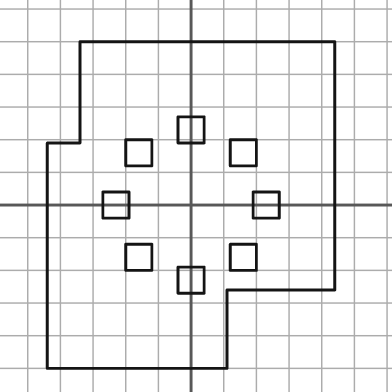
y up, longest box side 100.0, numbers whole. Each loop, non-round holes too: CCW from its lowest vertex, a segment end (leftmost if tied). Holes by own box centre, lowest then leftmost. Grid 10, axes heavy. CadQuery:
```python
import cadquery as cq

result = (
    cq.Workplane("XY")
    .moveTo(-44.0, -50.0)
    .lineTo(11.0, -50.0)
    .lineTo(11.0, -26.0)
    .lineTo(44.0, -26.0)
    .lineTo(44.0, 50.0)
    .lineTo(-34.0, 50.0)
    .lineTo(-34.0, 19.0)
    .lineTo(-44.0, 19.0)
    .close()
    .moveTo(-4.0, -27.0)
    .lineTo(4.0, -27.0)
    .lineTo(4.0, -19.0)
    .lineTo(-4.0, -19.0)
    .close()
    .moveTo(-20.0, -20.0)
    .lineTo(-12.0, -20.0)
    .lineTo(-12.0, -12.0)
    .lineTo(-20.0, -12.0)
    .close()
    .moveTo(12.0, -20.0)
    .lineTo(20.0, -20.0)
    .lineTo(20.0, -12.0)
    .lineTo(12.0, -12.0)
    .close()
    .moveTo(-27.0, -4.0)
    .lineTo(-19.0, -4.0)
    .lineTo(-19.0, 4.0)
    .lineTo(-27.0, 4.0)
    .close()
    .moveTo(19.0, -4.0)
    .lineTo(27.0, -4.0)
    .lineTo(27.0, 4.0)
    .lineTo(19.0, 4.0)
    .close()
    .moveTo(-20.0, 12.0)
    .lineTo(-12.0, 12.0)
    .lineTo(-12.0, 20.0)
    .lineTo(-20.0, 20.0)
    .close()
    .moveTo(12.0, 12.0)
    .lineTo(20.0, 12.0)
    .lineTo(20.0, 20.0)
    .lineTo(12.0, 20.0)
    .close()
    .moveTo(-4.0, 19.0)
    .lineTo(4.0, 19.0)
    .lineTo(4.0, 27.0)
    .lineTo(-4.0, 27.0)
    .close()
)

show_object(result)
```